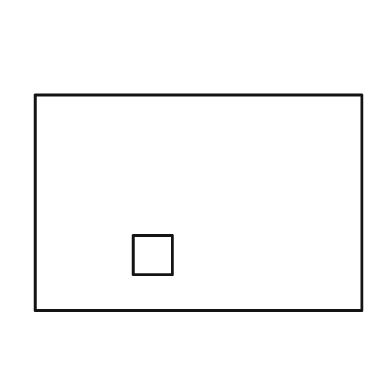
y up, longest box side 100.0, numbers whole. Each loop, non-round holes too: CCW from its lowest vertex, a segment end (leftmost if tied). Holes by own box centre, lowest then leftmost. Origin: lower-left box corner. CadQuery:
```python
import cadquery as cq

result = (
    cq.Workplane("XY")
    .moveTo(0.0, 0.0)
    .lineTo(100.0, 0.0)
    .lineTo(100.0, 66.0)
    .lineTo(0.0, 66.0)
    .close()
    .moveTo(30.0, 11.0)
    .lineTo(42.0, 11.0)
    .lineTo(42.0, 23.0)
    .lineTo(30.0, 23.0)
    .close()
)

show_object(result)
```